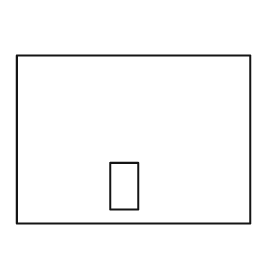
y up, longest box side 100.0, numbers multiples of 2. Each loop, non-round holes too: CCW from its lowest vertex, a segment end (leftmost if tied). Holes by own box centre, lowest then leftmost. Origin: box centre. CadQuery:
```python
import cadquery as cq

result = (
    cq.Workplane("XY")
    .moveTo(-50.0, -36.0)
    .lineTo(50.0, -36.0)
    .lineTo(50.0, 36.0)
    .lineTo(-50.0, 36.0)
    .close()
    .moveTo(-10.0, -30.0)
    .lineTo(2.0, -30.0)
    .lineTo(2.0, -10.0)
    .lineTo(-10.0, -10.0)
    .close()
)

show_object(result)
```